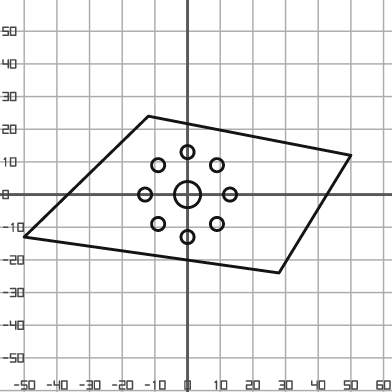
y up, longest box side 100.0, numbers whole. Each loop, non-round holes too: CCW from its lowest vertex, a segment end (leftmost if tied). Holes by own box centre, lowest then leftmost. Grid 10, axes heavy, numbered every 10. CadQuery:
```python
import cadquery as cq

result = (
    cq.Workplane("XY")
    .moveTo(28.0, -24.0)
    .lineTo(50.0, 12.0)
    .lineTo(-12.0, 24.0)
    .lineTo(-50.0, -13.0)
    .close()
    .moveTo(0.0, -13.0)
    .circle(2.0)
    .moveTo(-9.0, -9.0)
    .circle(2.0)
    .moveTo(9.0, -9.0)
    .circle(2.0)
    .moveTo(-13.0, 0.0)
    .circle(2.0)
    .moveTo(0.0, 0.0)
    .circle(4.0)
    .moveTo(13.0, 0.0)
    .circle(2.0)
    .moveTo(-9.0, 9.0)
    .circle(2.0)
    .moveTo(9.0, 9.0)
    .circle(2.0)
    .moveTo(0.0, 13.0)
    .circle(2.0)
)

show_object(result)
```